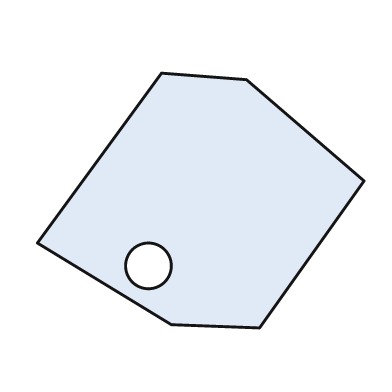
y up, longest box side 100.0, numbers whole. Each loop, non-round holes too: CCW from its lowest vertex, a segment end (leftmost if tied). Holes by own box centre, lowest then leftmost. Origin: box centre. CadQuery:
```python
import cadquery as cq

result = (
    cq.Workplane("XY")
    .moveTo(18.0, -39.0)
    .lineTo(50.0, 6.0)
    .lineTo(14.0, 37.0)
    .lineTo(-12.0, 39.0)
    .lineTo(-50.0, -13.0)
    .lineTo(-9.0, -38.0)
    .close()
    .moveTo(-16.0, -20.0)
    .circle(7.0)
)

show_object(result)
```